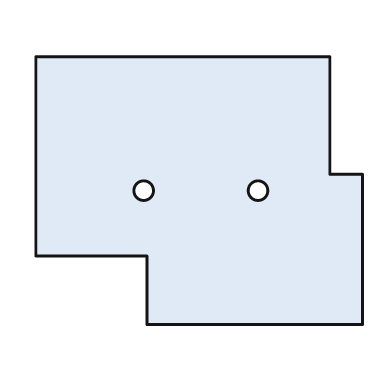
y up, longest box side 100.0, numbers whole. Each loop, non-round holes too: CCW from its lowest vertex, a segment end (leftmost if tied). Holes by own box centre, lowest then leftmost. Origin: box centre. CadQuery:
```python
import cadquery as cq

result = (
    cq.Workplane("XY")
    .moveTo(-16.0, -41.0)
    .lineTo(50.0, -41.0)
    .lineTo(50.0, 5.0)
    .lineTo(40.0, 5.0)
    .lineTo(40.0, 41.0)
    .lineTo(-50.0, 41.0)
    .lineTo(-50.0, -20.0)
    .lineTo(-16.0, -20.0)
    .close()
    .moveTo(-17.0, 0.0)
    .circle(3.0)
    .moveTo(18.0, 0.0)
    .circle(3.0)
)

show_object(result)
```